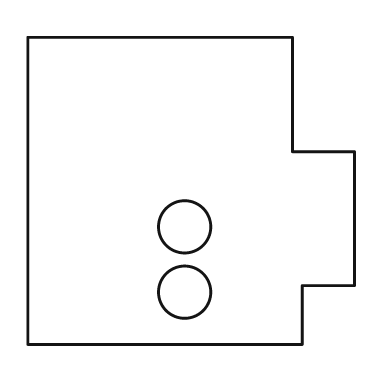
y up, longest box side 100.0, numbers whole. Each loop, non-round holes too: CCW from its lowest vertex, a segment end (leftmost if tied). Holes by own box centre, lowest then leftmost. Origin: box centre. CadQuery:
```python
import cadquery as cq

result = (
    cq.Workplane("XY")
    .moveTo(-50.0, -47.0)
    .lineTo(34.0, -47.0)
    .lineTo(34.0, -29.0)
    .lineTo(50.0, -29.0)
    .lineTo(50.0, 12.0)
    .lineTo(31.0, 12.0)
    .lineTo(31.0, 47.0)
    .lineTo(-50.0, 47.0)
    .close()
    .moveTo(-2.0, -31.0)
    .circle(8.0)
    .moveTo(-2.0, -11.0)
    .circle(8.0)
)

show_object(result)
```